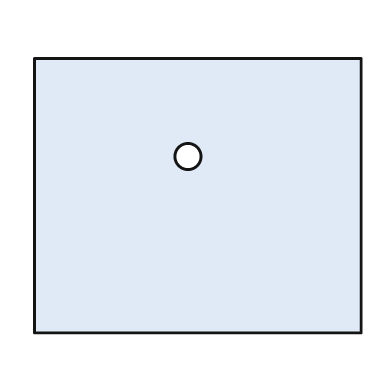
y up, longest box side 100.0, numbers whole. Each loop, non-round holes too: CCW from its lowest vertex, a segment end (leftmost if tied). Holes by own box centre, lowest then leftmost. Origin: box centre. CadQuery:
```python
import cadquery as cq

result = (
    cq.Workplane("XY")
    .moveTo(-50.0, -42.0)
    .lineTo(50.0, -42.0)
    .lineTo(50.0, 42.0)
    .lineTo(-50.0, 42.0)
    .close()
    .moveTo(-3.0, 12.0)
    .circle(4.0)
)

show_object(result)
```